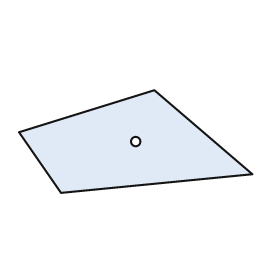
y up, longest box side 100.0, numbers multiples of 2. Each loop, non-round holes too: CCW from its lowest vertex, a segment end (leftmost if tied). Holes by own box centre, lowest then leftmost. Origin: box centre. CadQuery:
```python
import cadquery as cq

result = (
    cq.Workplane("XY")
    .moveTo(-32.0, -22.0)
    .lineTo(50.0, -14.0)
    .lineTo(8.0, 22.0)
    .lineTo(-50.0, 4.0)
    .close()
    .moveTo(0.0, 0.0)
    .circle(2.0)
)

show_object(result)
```